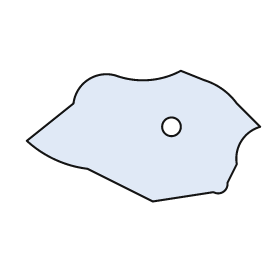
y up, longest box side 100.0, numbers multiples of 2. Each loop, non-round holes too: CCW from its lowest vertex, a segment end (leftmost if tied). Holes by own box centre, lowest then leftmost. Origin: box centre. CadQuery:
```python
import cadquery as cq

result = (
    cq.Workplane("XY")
    .moveTo(4.0, -28.0)
    .lineTo(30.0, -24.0)
    .threePointArc((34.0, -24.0), (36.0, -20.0))
    .lineTo(40.0, -12.0)
    .threePointArc((42.0, -2.0), (50.0, 4.0))
    .lineTo(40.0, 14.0)
    .threePointArc((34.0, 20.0), (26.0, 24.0))
    .lineTo(16.0, 28.0)
    .threePointArc((2.0, 24.0), (-12.0, 26.0))
    .threePointArc((-24.0, 24.0), (-30.0, 14.0))
    .lineTo(-50.0, -2.0)
    .threePointArc((-38.0, -10.0), (-24.0, -14.0))
    .close()
    .moveTo(12.0, 4.0)
    .circle(4.0)
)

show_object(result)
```